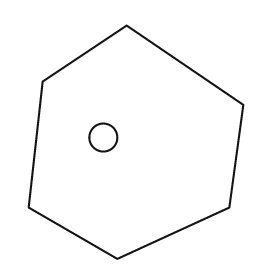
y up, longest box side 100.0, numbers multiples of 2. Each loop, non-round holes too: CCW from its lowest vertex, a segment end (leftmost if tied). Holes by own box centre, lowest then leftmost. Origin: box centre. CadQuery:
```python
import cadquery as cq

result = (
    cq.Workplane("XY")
    .moveTo(-8.0, -50.0)
    .lineTo(40.0, -28.0)
    .lineTo(46.0, 16.0)
    .lineTo(-4.0, 50.0)
    .lineTo(-40.0, 26.0)
    .lineTo(-46.0, -28.0)
    .close()
    .moveTo(-14.0, 2.0)
    .circle(6.0)
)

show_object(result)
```